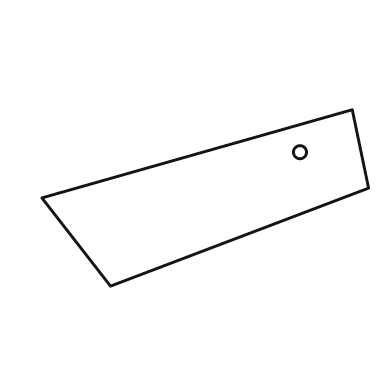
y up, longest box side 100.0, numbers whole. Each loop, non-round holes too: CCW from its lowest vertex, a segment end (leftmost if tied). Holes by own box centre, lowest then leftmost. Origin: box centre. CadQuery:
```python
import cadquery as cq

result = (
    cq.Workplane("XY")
    .moveTo(-29.0, -27.0)
    .lineTo(50.0, 3.0)
    .lineTo(45.0, 27.0)
    .lineTo(-50.0, 0.0)
    .close()
    .moveTo(29.0, 14.0)
    .circle(2.0)
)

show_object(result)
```